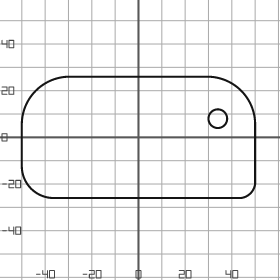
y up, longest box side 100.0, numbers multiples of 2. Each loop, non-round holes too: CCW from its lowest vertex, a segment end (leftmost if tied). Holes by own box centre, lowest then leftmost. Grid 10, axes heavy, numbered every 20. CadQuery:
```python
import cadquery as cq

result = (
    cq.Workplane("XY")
    .moveTo(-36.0, -26.0)
    .lineTo(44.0, -26.0)
    .threePointArc((48.0, -24.0), (50.0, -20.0))
    .lineTo(50.0, 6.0)
    .threePointArc((44.0, 20.0), (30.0, 26.0))
    .lineTo(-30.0, 26.0)
    .threePointArc((-44.0, 20.0), (-50.0, 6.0))
    .lineTo(-50.0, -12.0)
    .threePointArc((-46.0, -22.0), (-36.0, -26.0))
    .close()
    .moveTo(34.0, 8.0)
    .circle(4.0)
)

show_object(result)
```